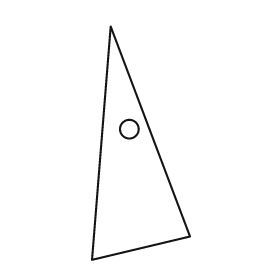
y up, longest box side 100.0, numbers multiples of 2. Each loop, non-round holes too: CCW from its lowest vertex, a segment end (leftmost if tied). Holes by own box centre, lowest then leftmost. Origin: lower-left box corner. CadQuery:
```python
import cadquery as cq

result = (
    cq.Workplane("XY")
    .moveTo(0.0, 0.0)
    .lineTo(42.0, 10.0)
    .lineTo(8.0, 100.0)
    .close()
    .moveTo(16.0, 56.0)
    .circle(4.0)
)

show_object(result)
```